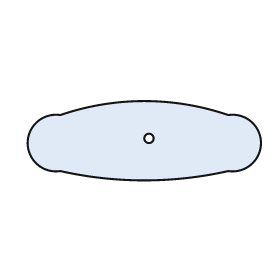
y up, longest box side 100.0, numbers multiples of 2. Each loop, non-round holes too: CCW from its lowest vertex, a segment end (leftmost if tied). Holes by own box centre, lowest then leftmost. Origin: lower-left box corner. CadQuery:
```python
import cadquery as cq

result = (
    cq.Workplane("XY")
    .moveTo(14.0, 4.0)
    .threePointArc((50.0, 0.0), (86.0, 4.0))
    .threePointArc((100.0, 16.0), (86.0, 28.0))
    .threePointArc((50.0, 34.0), (14.0, 28.0))
    .threePointArc((0.0, 16.0), (14.0, 4.0))
    .close()
    .moveTo(52.0, 18.0)
    .circle(2.0)
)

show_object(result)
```